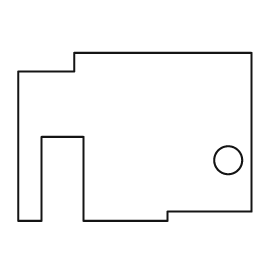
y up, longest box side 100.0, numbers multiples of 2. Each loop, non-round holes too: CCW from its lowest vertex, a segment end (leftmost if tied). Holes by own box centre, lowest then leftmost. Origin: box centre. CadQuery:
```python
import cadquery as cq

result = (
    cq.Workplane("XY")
    .moveTo(-50.0, -36.0)
    .lineTo(-40.0, -36.0)
    .lineTo(-40.0, 0.0)
    .lineTo(-22.0, 0.0)
    .lineTo(-22.0, -36.0)
    .lineTo(14.0, -36.0)
    .lineTo(14.0, -32.0)
    .lineTo(50.0, -32.0)
    .lineTo(50.0, 36.0)
    .lineTo(-26.0, 36.0)
    .lineTo(-26.0, 28.0)
    .lineTo(-50.0, 28.0)
    .close()
    .moveTo(40.0, -10.0)
    .circle(6.0)
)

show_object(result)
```